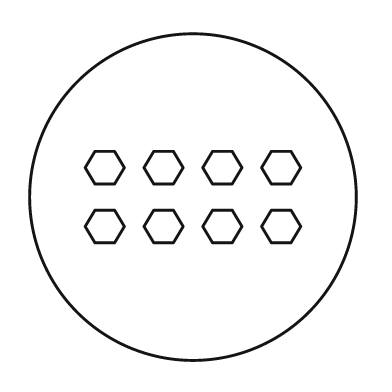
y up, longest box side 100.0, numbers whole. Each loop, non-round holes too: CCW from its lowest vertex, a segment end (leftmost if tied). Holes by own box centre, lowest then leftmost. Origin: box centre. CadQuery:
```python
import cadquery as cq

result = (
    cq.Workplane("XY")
    .moveTo(0.0, 0.0)
    .circle(50.0)
    .moveTo(-30.0, -14.0)
    .lineTo(-24.0, -14.0)
    .lineTo(-21.0, -9.0)
    .lineTo(-24.0, -4.0)
    .lineTo(-30.0, -4.0)
    .lineTo(-33.0, -9.0)
    .close()
    .moveTo(-12.0, -14.0)
    .lineTo(-6.0, -14.0)
    .lineTo(-3.0, -9.0)
    .lineTo(-6.0, -4.0)
    .lineTo(-12.0, -4.0)
    .lineTo(-15.0, -9.0)
    .close()
    .moveTo(6.0, -14.0)
    .lineTo(12.0, -14.0)
    .lineTo(15.0, -9.0)
    .lineTo(12.0, -4.0)
    .lineTo(6.0, -4.0)
    .lineTo(3.0, -9.0)
    .close()
    .moveTo(24.0, -14.0)
    .lineTo(30.0, -14.0)
    .lineTo(33.0, -9.0)
    .lineTo(30.0, -4.0)
    .lineTo(24.0, -4.0)
    .lineTo(21.0, -9.0)
    .close()
    .moveTo(-30.0, 4.0)
    .lineTo(-24.0, 4.0)
    .lineTo(-21.0, 9.0)
    .lineTo(-24.0, 14.0)
    .lineTo(-30.0, 14.0)
    .lineTo(-33.0, 9.0)
    .close()
    .moveTo(-12.0, 4.0)
    .lineTo(-6.0, 4.0)
    .lineTo(-3.0, 9.0)
    .lineTo(-6.0, 14.0)
    .lineTo(-12.0, 14.0)
    .lineTo(-15.0, 9.0)
    .close()
    .moveTo(6.0, 4.0)
    .lineTo(12.0, 4.0)
    .lineTo(15.0, 9.0)
    .lineTo(12.0, 14.0)
    .lineTo(6.0, 14.0)
    .lineTo(3.0, 9.0)
    .close()
    .moveTo(24.0, 4.0)
    .lineTo(30.0, 4.0)
    .lineTo(33.0, 9.0)
    .lineTo(30.0, 14.0)
    .lineTo(24.0, 14.0)
    .lineTo(21.0, 9.0)
    .close()
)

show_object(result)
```